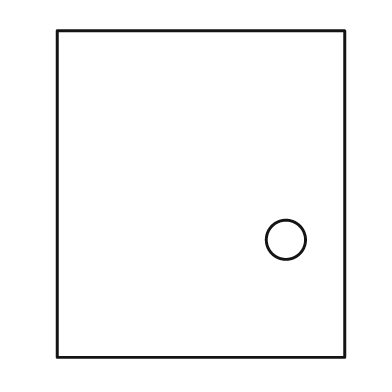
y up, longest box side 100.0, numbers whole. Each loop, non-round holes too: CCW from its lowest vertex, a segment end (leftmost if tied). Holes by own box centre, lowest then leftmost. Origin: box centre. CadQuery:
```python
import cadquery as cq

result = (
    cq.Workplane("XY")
    .moveTo(-44.0, -50.0)
    .lineTo(44.0, -50.0)
    .lineTo(44.0, 50.0)
    .lineTo(-44.0, 50.0)
    .close()
    .moveTo(26.0, -14.0)
    .circle(6.0)
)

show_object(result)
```